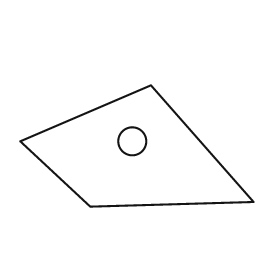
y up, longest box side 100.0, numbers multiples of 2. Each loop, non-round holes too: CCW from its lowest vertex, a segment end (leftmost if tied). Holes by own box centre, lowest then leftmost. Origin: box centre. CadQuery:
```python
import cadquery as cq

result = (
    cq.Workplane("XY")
    .moveTo(-20.0, -26.0)
    .lineTo(50.0, -24.0)
    .lineTo(6.0, 26.0)
    .lineTo(-50.0, 2.0)
    .close()
    .moveTo(-2.0, 2.0)
    .circle(6.0)
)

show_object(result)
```